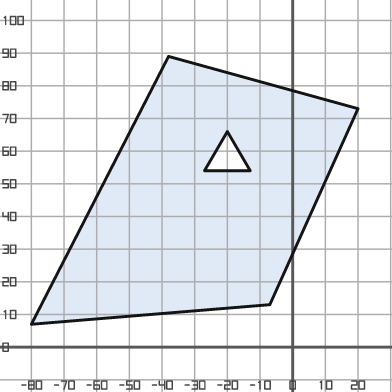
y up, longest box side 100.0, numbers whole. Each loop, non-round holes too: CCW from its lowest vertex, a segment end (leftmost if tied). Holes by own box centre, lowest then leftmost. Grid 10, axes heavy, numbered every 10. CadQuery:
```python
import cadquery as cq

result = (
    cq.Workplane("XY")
    .moveTo(-80.0, 7.0)
    .lineTo(-7.0, 13.0)
    .lineTo(20.0, 73.0)
    .lineTo(-38.0, 89.0)
    .close()
    .moveTo(-27.0, 54.0)
    .lineTo(-13.0, 54.0)
    .lineTo(-20.0, 66.0)
    .close()
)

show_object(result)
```